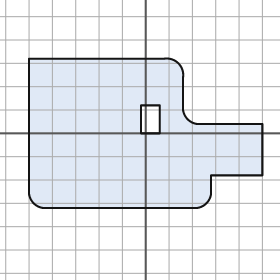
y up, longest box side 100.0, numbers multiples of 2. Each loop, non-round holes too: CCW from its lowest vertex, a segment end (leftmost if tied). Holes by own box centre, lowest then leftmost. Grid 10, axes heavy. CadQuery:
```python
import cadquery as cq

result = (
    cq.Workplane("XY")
    .moveTo(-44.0, -32.0)
    .lineTo(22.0, -32.0)
    .threePointArc((26.0, -30.0), (28.0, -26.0))
    .lineTo(28.0, -18.0)
    .lineTo(50.0, -18.0)
    .lineTo(50.0, 4.0)
    .lineTo(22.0, 4.0)
    .threePointArc((18.0, 6.0), (16.0, 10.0))
    .lineTo(16.0, 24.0)
    .threePointArc((14.0, 30.0), (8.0, 32.0))
    .lineTo(-50.0, 32.0)
    .lineTo(-50.0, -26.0)
    .threePointArc((-48.0, -30.0), (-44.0, -32.0))
    .close()
    .moveTo(-2.0, 0.0)
    .lineTo(6.0, 0.0)
    .lineTo(6.0, 12.0)
    .lineTo(-2.0, 12.0)
    .close()
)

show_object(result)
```